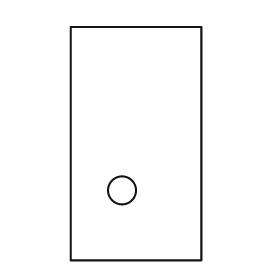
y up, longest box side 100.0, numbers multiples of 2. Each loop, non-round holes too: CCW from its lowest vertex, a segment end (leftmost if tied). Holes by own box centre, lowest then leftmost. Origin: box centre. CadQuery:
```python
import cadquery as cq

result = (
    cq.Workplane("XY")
    .moveTo(-28.0, -50.0)
    .lineTo(28.0, -50.0)
    .lineTo(28.0, 50.0)
    .lineTo(-28.0, 50.0)
    .close()
    .moveTo(-6.0, -20.0)
    .circle(6.0)
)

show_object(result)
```